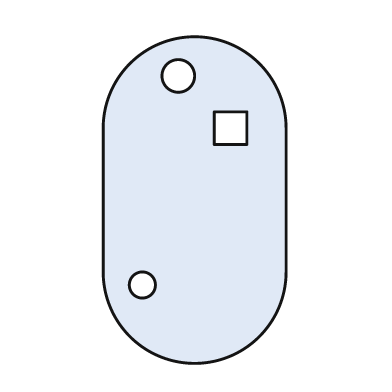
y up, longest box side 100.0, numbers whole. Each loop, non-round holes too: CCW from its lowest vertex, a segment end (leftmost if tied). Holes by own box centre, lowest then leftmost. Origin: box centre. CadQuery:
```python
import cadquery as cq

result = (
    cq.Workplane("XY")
    .moveTo(-28.0, -22.0)
    .threePointArc((0.0, -50.0), (28.0, -22.0))
    .lineTo(28.0, 22.0)
    .threePointArc((0.0, 50.0), (-28.0, 22.0))
    .close()
    .moveTo(-16.0, -26.0)
    .circle(4.0)
    .moveTo(6.0, 17.0)
    .lineTo(16.0, 17.0)
    .lineTo(16.0, 27.0)
    .lineTo(6.0, 27.0)
    .close()
    .moveTo(-5.0, 38.0)
    .circle(5.0)
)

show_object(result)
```